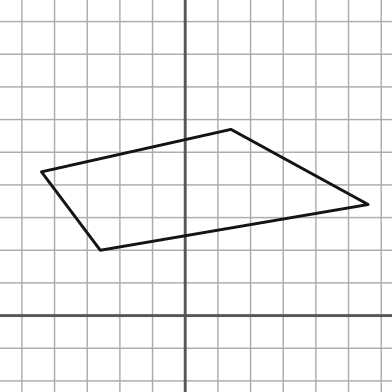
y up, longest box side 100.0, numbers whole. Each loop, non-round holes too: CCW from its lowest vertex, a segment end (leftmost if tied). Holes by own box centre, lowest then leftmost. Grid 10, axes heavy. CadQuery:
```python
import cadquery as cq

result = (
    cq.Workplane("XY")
    .moveTo(-26.0, 20.0)
    .lineTo(56.0, 34.0)
    .lineTo(14.0, 57.0)
    .lineTo(-44.0, 44.0)
    .close()
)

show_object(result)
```